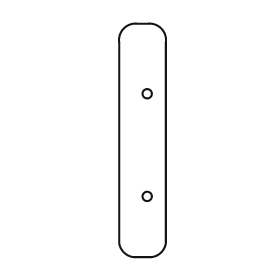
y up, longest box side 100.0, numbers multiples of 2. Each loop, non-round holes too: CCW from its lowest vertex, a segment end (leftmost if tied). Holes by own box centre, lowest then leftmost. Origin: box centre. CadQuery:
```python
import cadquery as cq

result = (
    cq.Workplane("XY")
    .moveTo(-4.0, -50.0)
    .lineTo(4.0, -50.0)
    .threePointArc((8.0, -48.0), (10.0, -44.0))
    .lineTo(10.0, 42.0)
    .threePointArc((8.0, 48.0), (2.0, 50.0))
    .lineTo(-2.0, 50.0)
    .threePointArc((-8.0, 48.0), (-10.0, 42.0))
    .lineTo(-10.0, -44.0)
    .threePointArc((-8.0, -48.0), (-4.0, -50.0))
    .close()
    .moveTo(2.0, -24.0)
    .circle(2.0)
    .moveTo(2.0, 20.0)
    .circle(2.0)
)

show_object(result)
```